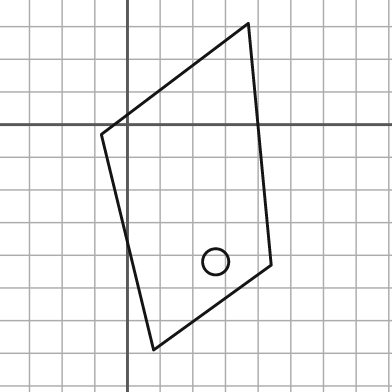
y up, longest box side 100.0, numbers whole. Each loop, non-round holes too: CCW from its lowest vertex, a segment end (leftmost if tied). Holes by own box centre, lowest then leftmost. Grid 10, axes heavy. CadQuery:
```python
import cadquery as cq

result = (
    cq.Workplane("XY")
    .moveTo(8.0, -69.0)
    .lineTo(44.0, -43.0)
    .lineTo(37.0, 31.0)
    .lineTo(-8.0, -3.0)
    .close()
    .moveTo(27.0, -42.0)
    .circle(4.0)
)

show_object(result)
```